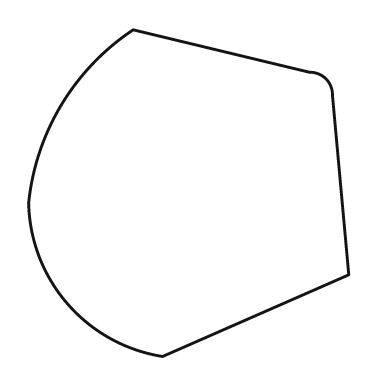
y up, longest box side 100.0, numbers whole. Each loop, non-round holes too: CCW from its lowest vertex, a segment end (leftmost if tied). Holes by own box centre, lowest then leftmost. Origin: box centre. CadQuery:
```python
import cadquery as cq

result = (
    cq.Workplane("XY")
    .moveTo(-8.0, -50.0)
    .lineTo(49.0, -25.0)
    .lineTo(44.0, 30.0)
    .threePointArc((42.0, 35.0), (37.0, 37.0))
    .lineTo(-17.0, 50.0)
    .threePointArc((-39.0, 27.0), (-49.0, -3.0))
    .threePointArc((-37.0, -34.0), (-8.0, -50.0))
    .close()
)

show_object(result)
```